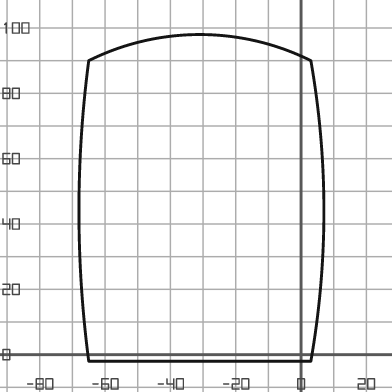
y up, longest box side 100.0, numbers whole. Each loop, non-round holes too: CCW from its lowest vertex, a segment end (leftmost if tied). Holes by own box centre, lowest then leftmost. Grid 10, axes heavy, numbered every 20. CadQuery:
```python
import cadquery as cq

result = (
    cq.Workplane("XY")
    .moveTo(-65.0, -2.0)
    .lineTo(3.0, -2.0)
    .threePointArc((7.0, 44.0), (3.0, 90.0))
    .threePointArc((-31.0, 98.0), (-65.0, 90.0))
    .threePointArc((-68.0, 44.0), (-65.0, -2.0))
    .close()
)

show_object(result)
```